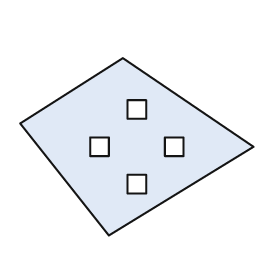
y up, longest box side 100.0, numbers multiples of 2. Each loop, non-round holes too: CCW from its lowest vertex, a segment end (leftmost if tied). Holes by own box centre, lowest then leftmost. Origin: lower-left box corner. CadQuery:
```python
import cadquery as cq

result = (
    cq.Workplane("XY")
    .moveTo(38.0, 0.0)
    .lineTo(100.0, 38.0)
    .lineTo(44.0, 76.0)
    .lineTo(0.0, 48.0)
    .close()
    .moveTo(46.0, 18.0)
    .lineTo(54.0, 18.0)
    .lineTo(54.0, 26.0)
    .lineTo(46.0, 26.0)
    .close()
    .moveTo(30.0, 34.0)
    .lineTo(38.0, 34.0)
    .lineTo(38.0, 42.0)
    .lineTo(30.0, 42.0)
    .close()
    .moveTo(62.0, 34.0)
    .lineTo(70.0, 34.0)
    .lineTo(70.0, 42.0)
    .lineTo(62.0, 42.0)
    .close()
    .moveTo(46.0, 50.0)
    .lineTo(54.0, 50.0)
    .lineTo(54.0, 58.0)
    .lineTo(46.0, 58.0)
    .close()
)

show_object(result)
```